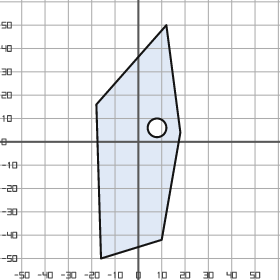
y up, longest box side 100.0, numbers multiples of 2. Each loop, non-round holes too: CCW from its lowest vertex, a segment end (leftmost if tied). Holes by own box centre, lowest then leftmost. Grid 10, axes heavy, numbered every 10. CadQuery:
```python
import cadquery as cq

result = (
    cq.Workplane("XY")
    .moveTo(-16.0, -50.0)
    .lineTo(10.0, -42.0)
    .lineTo(18.0, 4.0)
    .lineTo(12.0, 50.0)
    .lineTo(-18.0, 16.0)
    .close()
    .moveTo(8.0, 6.0)
    .circle(4.0)
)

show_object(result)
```